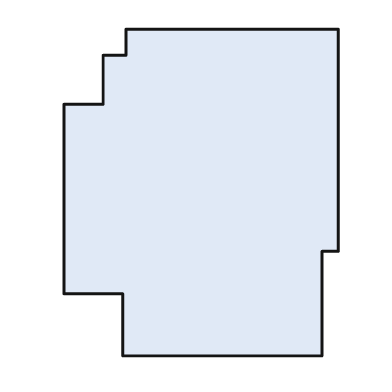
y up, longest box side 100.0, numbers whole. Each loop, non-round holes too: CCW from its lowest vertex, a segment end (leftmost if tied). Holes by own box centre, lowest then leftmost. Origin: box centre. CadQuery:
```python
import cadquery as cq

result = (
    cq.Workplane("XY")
    .moveTo(-24.0, -50.0)
    .lineTo(37.0, -50.0)
    .lineTo(37.0, -18.0)
    .lineTo(42.0, -18.0)
    .lineTo(42.0, 50.0)
    .lineTo(-23.0, 50.0)
    .lineTo(-23.0, 42.0)
    .lineTo(-30.0, 42.0)
    .lineTo(-30.0, 27.0)
    .lineTo(-42.0, 27.0)
    .lineTo(-42.0, -31.0)
    .lineTo(-24.0, -31.0)
    .close()
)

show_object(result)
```